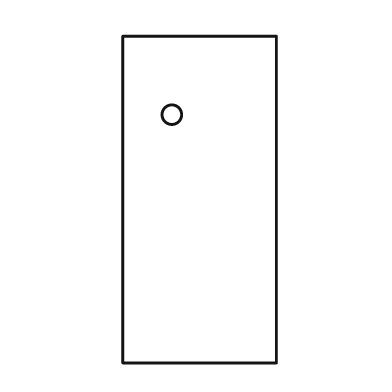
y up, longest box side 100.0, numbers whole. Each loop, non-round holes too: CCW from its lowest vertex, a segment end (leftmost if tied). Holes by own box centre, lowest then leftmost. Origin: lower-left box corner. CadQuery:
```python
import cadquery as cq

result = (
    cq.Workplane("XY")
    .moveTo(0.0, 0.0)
    .lineTo(47.0, 0.0)
    .lineTo(47.0, 100.0)
    .lineTo(0.0, 100.0)
    .close()
    .moveTo(15.0, 76.0)
    .circle(3.0)
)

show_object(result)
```